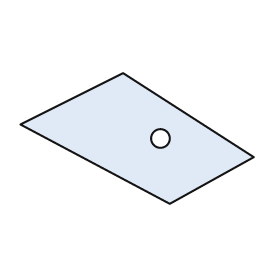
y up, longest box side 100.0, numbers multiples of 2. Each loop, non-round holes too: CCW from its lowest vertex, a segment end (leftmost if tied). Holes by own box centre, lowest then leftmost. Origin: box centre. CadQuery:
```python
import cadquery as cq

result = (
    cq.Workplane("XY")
    .moveTo(14.0, -28.0)
    .lineTo(50.0, -8.0)
    .lineTo(-6.0, 28.0)
    .lineTo(-50.0, 6.0)
    .close()
    .moveTo(10.0, 0.0)
    .circle(4.0)
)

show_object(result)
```